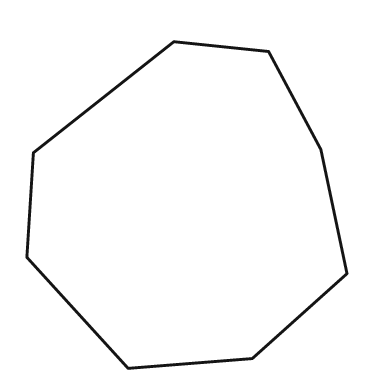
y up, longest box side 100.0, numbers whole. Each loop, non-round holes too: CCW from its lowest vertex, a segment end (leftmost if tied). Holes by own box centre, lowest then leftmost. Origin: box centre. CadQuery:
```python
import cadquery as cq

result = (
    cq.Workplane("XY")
    .moveTo(-18.0, -50.0)
    .lineTo(20.0, -47.0)
    .lineTo(49.0, -21.0)
    .lineTo(41.0, 17.0)
    .lineTo(25.0, 47.0)
    .lineTo(-4.0, 50.0)
    .lineTo(-47.0, 16.0)
    .lineTo(-49.0, -16.0)
    .close()
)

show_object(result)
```